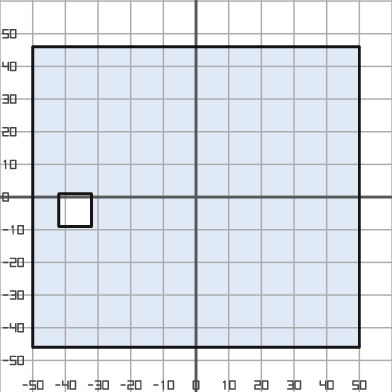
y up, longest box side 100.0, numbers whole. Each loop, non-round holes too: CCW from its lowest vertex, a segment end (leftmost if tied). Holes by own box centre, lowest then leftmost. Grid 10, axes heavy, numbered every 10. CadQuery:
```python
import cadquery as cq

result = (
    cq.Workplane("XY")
    .moveTo(-50.0, -46.0)
    .lineTo(50.0, -46.0)
    .lineTo(50.0, 46.0)
    .lineTo(-50.0, 46.0)
    .close()
    .moveTo(-42.0, -9.0)
    .lineTo(-32.0, -9.0)
    .lineTo(-32.0, 1.0)
    .lineTo(-42.0, 1.0)
    .close()
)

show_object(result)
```